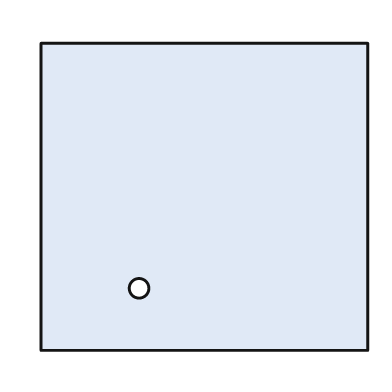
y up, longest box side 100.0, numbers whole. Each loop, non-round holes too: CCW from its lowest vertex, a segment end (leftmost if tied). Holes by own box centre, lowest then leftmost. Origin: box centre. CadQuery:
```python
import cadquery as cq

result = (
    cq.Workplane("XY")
    .moveTo(-50.0, -47.0)
    .lineTo(50.0, -47.0)
    .lineTo(50.0, 47.0)
    .lineTo(-50.0, 47.0)
    .close()
    .moveTo(-20.0, -28.0)
    .circle(3.0)
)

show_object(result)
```